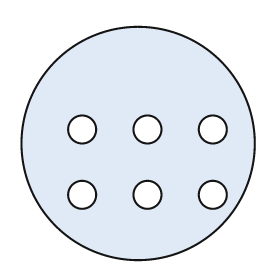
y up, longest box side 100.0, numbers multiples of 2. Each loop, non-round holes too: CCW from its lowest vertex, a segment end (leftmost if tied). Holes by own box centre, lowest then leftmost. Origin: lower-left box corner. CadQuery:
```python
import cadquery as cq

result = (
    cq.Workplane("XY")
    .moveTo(50.0, 50.0)
    .circle(50.0)
    .moveTo(26.0, 28.0)
    .circle(6.0)
    .moveTo(54.0, 28.0)
    .circle(6.0)
    .moveTo(82.0, 28.0)
    .circle(6.0)
    .moveTo(26.0, 56.0)
    .circle(6.0)
    .moveTo(54.0, 56.0)
    .circle(6.0)
    .moveTo(82.0, 56.0)
    .circle(6.0)
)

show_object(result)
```